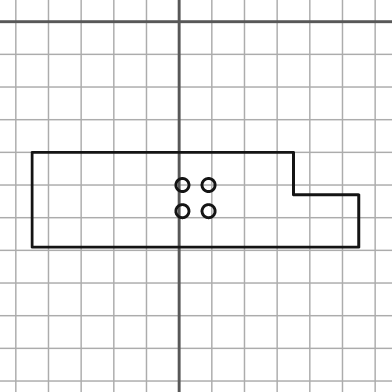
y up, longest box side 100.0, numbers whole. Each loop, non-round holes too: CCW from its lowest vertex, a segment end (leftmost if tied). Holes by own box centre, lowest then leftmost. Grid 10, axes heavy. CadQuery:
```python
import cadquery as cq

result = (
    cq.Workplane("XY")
    .moveTo(-45.0, -69.0)
    .lineTo(55.0, -69.0)
    .lineTo(55.0, -53.0)
    .lineTo(35.0, -53.0)
    .lineTo(35.0, -40.0)
    .lineTo(-45.0, -40.0)
    .close()
    .moveTo(1.0, -58.0)
    .circle(2.0)
    .moveTo(9.0, -58.0)
    .circle(2.0)
    .moveTo(1.0, -50.0)
    .circle(2.0)
    .moveTo(9.0, -50.0)
    .circle(2.0)
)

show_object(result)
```